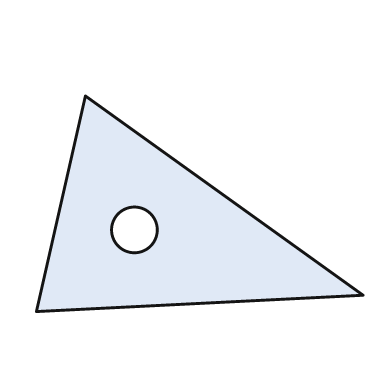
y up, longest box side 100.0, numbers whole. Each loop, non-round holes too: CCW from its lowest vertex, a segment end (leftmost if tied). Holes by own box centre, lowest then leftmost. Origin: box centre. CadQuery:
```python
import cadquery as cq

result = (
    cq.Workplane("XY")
    .moveTo(-50.0, -33.0)
    .lineTo(50.0, -28.0)
    .lineTo(-35.0, 33.0)
    .close()
    .moveTo(-20.0, -8.0)
    .circle(7.0)
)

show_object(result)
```